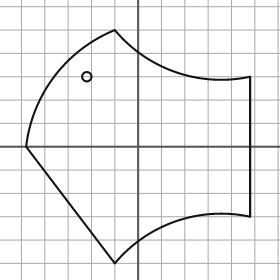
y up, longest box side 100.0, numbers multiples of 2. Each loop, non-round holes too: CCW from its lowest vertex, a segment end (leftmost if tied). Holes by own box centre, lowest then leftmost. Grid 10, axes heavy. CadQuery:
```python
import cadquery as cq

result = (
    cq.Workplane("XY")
    .moveTo(-10.0, -50.0)
    .threePointArc((16.0, -32.0), (48.0, -30.0))
    .lineTo(48.0, 30.0)
    .threePointArc((16.0, 32.0), (-10.0, 50.0))
    .threePointArc((-36.0, 30.0), (-48.0, 0.0))
    .close()
    .moveTo(-22.0, 30.0)
    .circle(2.0)
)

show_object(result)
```